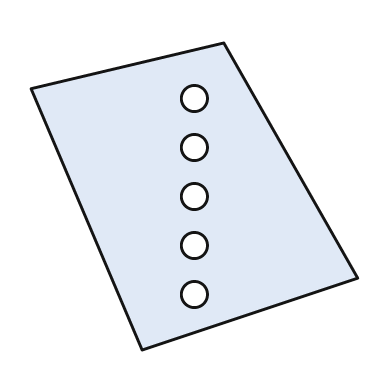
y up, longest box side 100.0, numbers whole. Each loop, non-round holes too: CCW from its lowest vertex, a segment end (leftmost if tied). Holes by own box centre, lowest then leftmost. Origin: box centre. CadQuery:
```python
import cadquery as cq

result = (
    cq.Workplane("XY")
    .moveTo(-16.0, -47.0)
    .lineTo(50.0, -25.0)
    .lineTo(9.0, 47.0)
    .lineTo(-50.0, 33.0)
    .close()
    .moveTo(0.0, -30.0)
    .circle(4.0)
    .moveTo(0.0, -15.0)
    .circle(4.0)
    .moveTo(0.0, 0.0)
    .circle(4.0)
    .moveTo(0.0, 15.0)
    .circle(4.0)
    .moveTo(0.0, 30.0)
    .circle(4.0)
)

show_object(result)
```